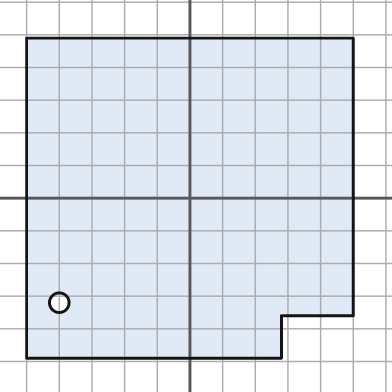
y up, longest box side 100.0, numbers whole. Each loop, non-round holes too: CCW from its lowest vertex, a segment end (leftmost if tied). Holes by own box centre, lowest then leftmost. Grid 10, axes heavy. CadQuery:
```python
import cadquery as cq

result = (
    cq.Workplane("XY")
    .moveTo(-50.0, -49.0)
    .lineTo(28.0, -49.0)
    .lineTo(28.0, -36.0)
    .lineTo(50.0, -36.0)
    .lineTo(50.0, 49.0)
    .lineTo(-50.0, 49.0)
    .close()
    .moveTo(-40.0, -32.0)
    .circle(3.0)
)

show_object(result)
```